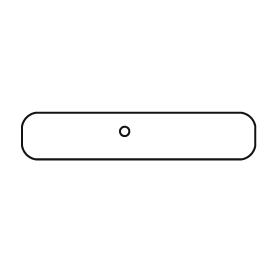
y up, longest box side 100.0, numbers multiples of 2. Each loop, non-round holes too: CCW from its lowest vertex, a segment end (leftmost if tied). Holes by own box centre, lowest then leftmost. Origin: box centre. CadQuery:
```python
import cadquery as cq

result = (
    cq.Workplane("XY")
    .moveTo(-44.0, -10.0)
    .lineTo(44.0, -10.0)
    .threePointArc((48.0, -8.0), (50.0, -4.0))
    .lineTo(50.0, 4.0)
    .threePointArc((48.0, 8.0), (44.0, 10.0))
    .lineTo(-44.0, 10.0)
    .threePointArc((-48.0, 8.0), (-50.0, 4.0))
    .lineTo(-50.0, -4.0)
    .threePointArc((-48.0, -8.0), (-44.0, -10.0))
    .close()
    .moveTo(-6.0, 2.0)
    .circle(2.0)
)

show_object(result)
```